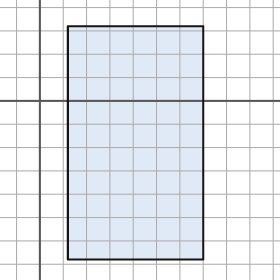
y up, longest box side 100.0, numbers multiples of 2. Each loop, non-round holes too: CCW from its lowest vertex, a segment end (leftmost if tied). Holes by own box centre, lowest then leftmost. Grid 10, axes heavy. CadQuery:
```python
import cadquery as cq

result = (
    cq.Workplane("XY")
    .moveTo(12.0, -68.0)
    .lineTo(70.0, -68.0)
    .lineTo(70.0, 32.0)
    .lineTo(12.0, 32.0)
    .close()
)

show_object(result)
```